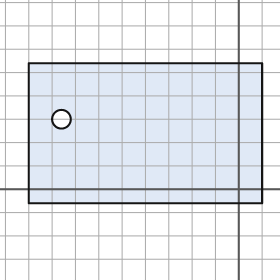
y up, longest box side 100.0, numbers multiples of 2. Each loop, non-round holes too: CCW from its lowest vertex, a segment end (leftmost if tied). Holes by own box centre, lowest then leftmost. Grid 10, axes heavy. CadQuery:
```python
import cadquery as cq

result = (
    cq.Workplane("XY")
    .moveTo(-90.0, -6.0)
    .lineTo(10.0, -6.0)
    .lineTo(10.0, 54.0)
    .lineTo(-90.0, 54.0)
    .close()
    .moveTo(-76.0, 30.0)
    .circle(4.0)
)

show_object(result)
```